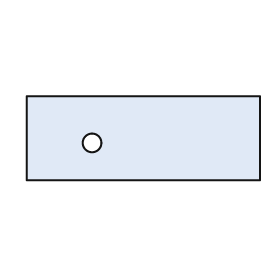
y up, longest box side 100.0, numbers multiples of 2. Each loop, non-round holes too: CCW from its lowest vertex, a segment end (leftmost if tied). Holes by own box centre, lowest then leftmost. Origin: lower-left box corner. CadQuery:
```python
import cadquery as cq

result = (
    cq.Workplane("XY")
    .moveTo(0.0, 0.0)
    .lineTo(100.0, 0.0)
    .lineTo(100.0, 36.0)
    .lineTo(0.0, 36.0)
    .close()
    .moveTo(28.0, 16.0)
    .circle(4.0)
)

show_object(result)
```